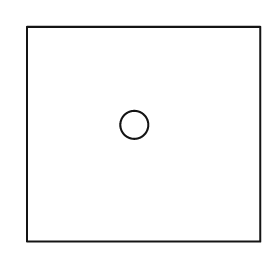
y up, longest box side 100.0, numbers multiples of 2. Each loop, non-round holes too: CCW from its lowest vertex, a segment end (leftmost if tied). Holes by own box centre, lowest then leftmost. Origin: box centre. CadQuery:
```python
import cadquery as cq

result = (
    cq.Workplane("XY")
    .moveTo(-50.0, -46.0)
    .lineTo(50.0, -46.0)
    .lineTo(50.0, 46.0)
    .lineTo(-50.0, 46.0)
    .close()
    .moveTo(-4.0, 4.0)
    .circle(6.0)
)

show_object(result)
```